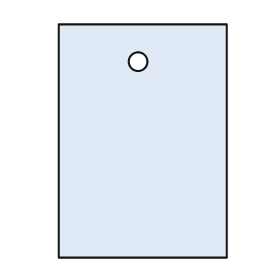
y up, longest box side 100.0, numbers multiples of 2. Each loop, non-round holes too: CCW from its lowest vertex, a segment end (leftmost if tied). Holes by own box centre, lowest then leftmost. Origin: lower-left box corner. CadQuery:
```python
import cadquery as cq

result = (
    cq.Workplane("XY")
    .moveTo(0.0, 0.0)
    .lineTo(72.0, 0.0)
    .lineTo(72.0, 100.0)
    .lineTo(0.0, 100.0)
    .close()
    .moveTo(34.0, 84.0)
    .circle(4.0)
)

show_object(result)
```